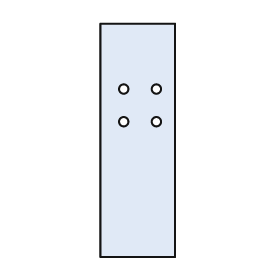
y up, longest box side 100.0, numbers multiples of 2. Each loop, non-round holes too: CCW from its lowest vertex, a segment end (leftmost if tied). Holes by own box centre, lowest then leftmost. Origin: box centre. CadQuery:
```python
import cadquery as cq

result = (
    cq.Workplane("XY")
    .moveTo(-16.0, -50.0)
    .lineTo(16.0, -50.0)
    .lineTo(16.0, 50.0)
    .lineTo(-16.0, 50.0)
    .close()
    .moveTo(-6.0, 8.0)
    .circle(2.0)
    .moveTo(8.0, 8.0)
    .circle(2.0)
    .moveTo(-6.0, 22.0)
    .circle(2.0)
    .moveTo(8.0, 22.0)
    .circle(2.0)
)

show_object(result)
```